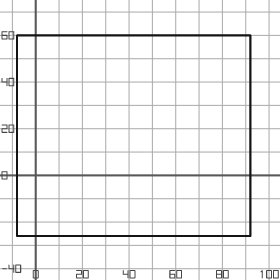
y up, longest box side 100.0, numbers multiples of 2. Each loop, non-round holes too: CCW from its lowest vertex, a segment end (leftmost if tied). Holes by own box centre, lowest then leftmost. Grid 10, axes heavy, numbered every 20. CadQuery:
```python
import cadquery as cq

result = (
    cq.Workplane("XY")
    .moveTo(-8.0, -26.0)
    .lineTo(92.0, -26.0)
    .lineTo(92.0, 60.0)
    .lineTo(-8.0, 60.0)
    .close()
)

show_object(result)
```